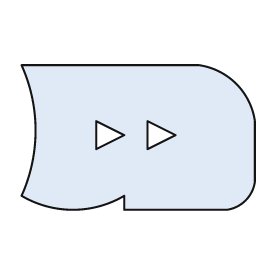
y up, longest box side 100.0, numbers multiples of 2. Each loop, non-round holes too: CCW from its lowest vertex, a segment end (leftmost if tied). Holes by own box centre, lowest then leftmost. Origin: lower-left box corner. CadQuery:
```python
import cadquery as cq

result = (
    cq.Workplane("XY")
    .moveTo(44.0, 0.0)
    .lineTo(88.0, 0.0)
    .threePointArc((96.0, 4.0), (100.0, 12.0))
    .lineTo(100.0, 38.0)
    .threePointArc((92.0, 54.0), (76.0, 62.0))
    .lineTo(0.0, 62.0)
    .threePointArc((6.0, 34.0), (0.0, 6.0))
    .threePointArc((22.0, 0.0), (44.0, 6.0))
    .close()
    .moveTo(32.0, 26.0)
    .lineTo(44.0, 32.0)
    .lineTo(32.0, 38.0)
    .close()
    .moveTo(54.0, 26.0)
    .lineTo(66.0, 32.0)
    .lineTo(54.0, 38.0)
    .close()
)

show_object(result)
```